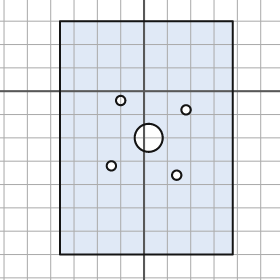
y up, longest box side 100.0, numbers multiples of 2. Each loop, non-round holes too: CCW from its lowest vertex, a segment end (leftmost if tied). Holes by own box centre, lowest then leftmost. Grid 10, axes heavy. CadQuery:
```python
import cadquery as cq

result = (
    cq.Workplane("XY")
    .moveTo(-36.0, -70.0)
    .lineTo(38.0, -70.0)
    .lineTo(38.0, 30.0)
    .lineTo(-36.0, 30.0)
    .close()
    .moveTo(14.0, -36.0)
    .circle(2.0)
    .moveTo(-14.0, -32.0)
    .circle(2.0)
    .moveTo(2.0, -20.0)
    .circle(6.0)
    .moveTo(18.0, -8.0)
    .circle(2.0)
    .moveTo(-10.0, -4.0)
    .circle(2.0)
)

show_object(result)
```